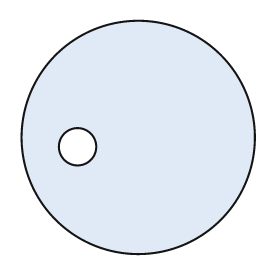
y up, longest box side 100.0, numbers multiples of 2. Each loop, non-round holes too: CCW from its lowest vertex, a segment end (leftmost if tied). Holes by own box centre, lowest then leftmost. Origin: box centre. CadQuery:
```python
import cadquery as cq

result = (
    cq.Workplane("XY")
    .moveTo(0.0, 0.0)
    .circle(50.0)
    .moveTo(-26.0, -4.0)
    .circle(8.0)
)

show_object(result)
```